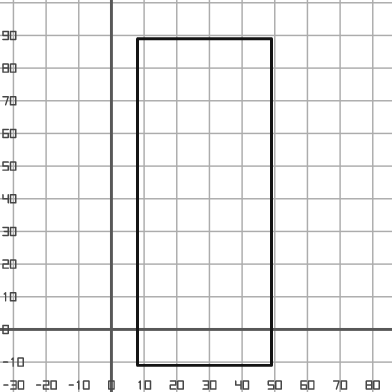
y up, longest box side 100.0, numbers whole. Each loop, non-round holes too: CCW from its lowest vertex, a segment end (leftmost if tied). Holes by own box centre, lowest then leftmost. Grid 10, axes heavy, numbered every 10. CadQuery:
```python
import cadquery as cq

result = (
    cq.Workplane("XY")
    .moveTo(8.0, -11.0)
    .lineTo(49.0, -11.0)
    .lineTo(49.0, 89.0)
    .lineTo(8.0, 89.0)
    .close()
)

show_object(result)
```